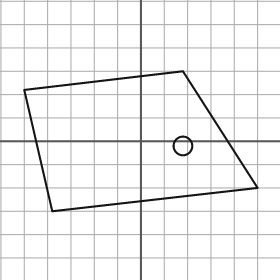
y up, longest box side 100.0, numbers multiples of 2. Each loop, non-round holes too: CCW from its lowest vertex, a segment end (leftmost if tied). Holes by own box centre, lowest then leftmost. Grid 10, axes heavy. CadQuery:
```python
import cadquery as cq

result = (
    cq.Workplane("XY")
    .moveTo(-38.0, -30.0)
    .lineTo(50.0, -20.0)
    .lineTo(18.0, 30.0)
    .lineTo(-50.0, 22.0)
    .close()
    .moveTo(18.0, -2.0)
    .circle(4.0)
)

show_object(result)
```